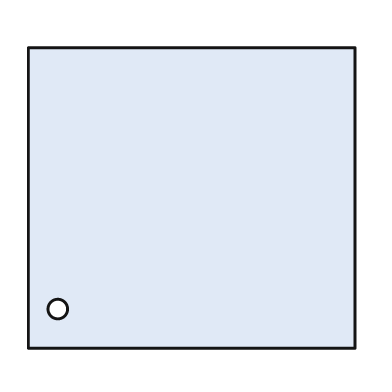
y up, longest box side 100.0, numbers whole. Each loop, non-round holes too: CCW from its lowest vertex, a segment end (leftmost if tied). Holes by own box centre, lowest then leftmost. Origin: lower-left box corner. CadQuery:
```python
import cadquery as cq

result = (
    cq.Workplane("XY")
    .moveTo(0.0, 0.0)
    .lineTo(100.0, 0.0)
    .lineTo(100.0, 92.0)
    .lineTo(0.0, 92.0)
    .close()
    .moveTo(9.0, 12.0)
    .circle(3.0)
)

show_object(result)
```